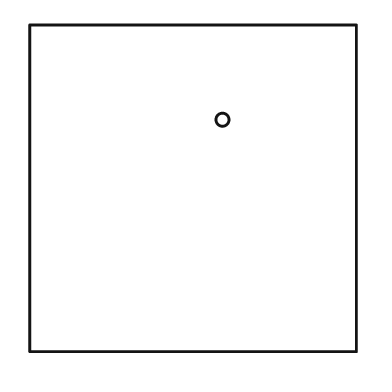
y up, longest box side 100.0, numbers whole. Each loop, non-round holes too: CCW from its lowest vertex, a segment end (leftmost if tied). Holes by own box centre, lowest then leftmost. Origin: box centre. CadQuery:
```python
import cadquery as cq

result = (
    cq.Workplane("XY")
    .moveTo(-50.0, -50.0)
    .lineTo(50.0, -50.0)
    .lineTo(50.0, 50.0)
    .lineTo(-50.0, 50.0)
    .close()
    .moveTo(9.0, 21.0)
    .circle(2.0)
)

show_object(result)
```